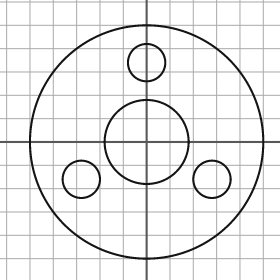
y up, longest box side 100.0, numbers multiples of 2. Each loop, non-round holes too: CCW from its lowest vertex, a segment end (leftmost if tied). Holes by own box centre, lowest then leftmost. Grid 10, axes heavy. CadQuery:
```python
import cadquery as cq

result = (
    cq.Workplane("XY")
    .moveTo(0.0, 0.0)
    .circle(50.0)
    .moveTo(-28.0, -16.0)
    .circle(8.0)
    .moveTo(28.0, -16.0)
    .circle(8.0)
    .moveTo(0.0, 0.0)
    .circle(18.0)
    .moveTo(0.0, 34.0)
    .circle(8.0)
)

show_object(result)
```